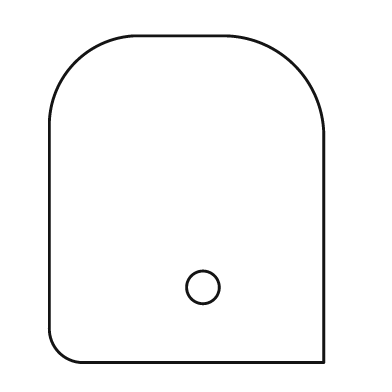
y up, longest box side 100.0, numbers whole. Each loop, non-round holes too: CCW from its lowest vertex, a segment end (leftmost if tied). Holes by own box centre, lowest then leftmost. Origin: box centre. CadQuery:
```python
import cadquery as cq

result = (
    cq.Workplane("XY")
    .moveTo(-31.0, -50.0)
    .lineTo(42.0, -50.0)
    .lineTo(42.0, 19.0)
    .threePointArc((33.0, 41.0), (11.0, 50.0))
    .lineTo(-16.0, 50.0)
    .threePointArc((-34.0, 42.0), (-42.0, 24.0))
    .lineTo(-42.0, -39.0)
    .threePointArc((-39.0, -47.0), (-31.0, -50.0))
    .close()
    .moveTo(5.0, -27.0)
    .circle(5.0)
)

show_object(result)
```